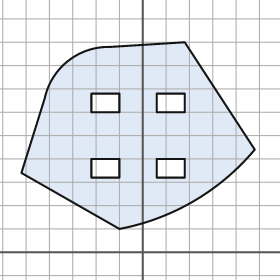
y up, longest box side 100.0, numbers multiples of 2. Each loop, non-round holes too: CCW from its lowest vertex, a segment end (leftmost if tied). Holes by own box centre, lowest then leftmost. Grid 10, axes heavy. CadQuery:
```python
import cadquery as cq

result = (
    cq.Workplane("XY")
    .moveTo(-10.0, 10.0)
    .threePointArc((22.0, 22.0), (48.0, 44.0))
    .lineTo(18.0, 90.0)
    .lineTo(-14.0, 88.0)
    .threePointArc((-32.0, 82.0), (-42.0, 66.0))
    .lineTo(-52.0, 34.0)
    .close()
    .moveTo(-22.0, 32.0)
    .lineTo(-10.0, 32.0)
    .lineTo(-10.0, 40.0)
    .lineTo(-22.0, 40.0)
    .close()
    .moveTo(6.0, 32.0)
    .lineTo(18.0, 32.0)
    .lineTo(18.0, 40.0)
    .lineTo(6.0, 40.0)
    .close()
    .moveTo(-22.0, 60.0)
    .lineTo(-10.0, 60.0)
    .lineTo(-10.0, 68.0)
    .lineTo(-22.0, 68.0)
    .close()
    .moveTo(6.0, 60.0)
    .lineTo(18.0, 60.0)
    .lineTo(18.0, 68.0)
    .lineTo(6.0, 68.0)
    .close()
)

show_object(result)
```